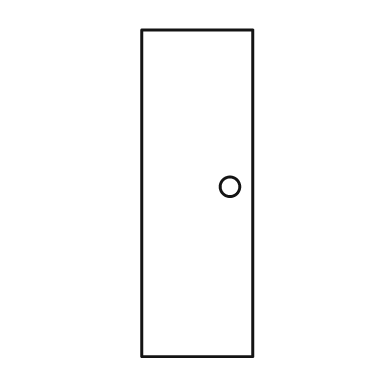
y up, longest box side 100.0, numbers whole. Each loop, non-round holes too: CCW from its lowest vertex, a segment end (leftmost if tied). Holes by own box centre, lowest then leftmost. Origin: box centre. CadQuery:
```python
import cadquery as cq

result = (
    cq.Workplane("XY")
    .moveTo(-17.0, -50.0)
    .lineTo(17.0, -50.0)
    .lineTo(17.0, 50.0)
    .lineTo(-17.0, 50.0)
    .close()
    .moveTo(10.0, 2.0)
    .circle(3.0)
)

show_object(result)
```